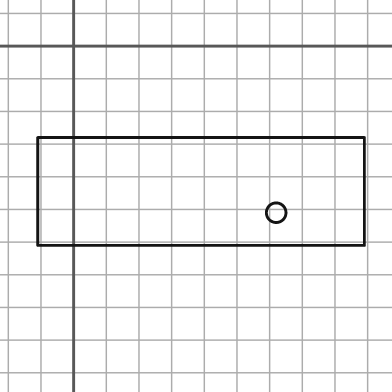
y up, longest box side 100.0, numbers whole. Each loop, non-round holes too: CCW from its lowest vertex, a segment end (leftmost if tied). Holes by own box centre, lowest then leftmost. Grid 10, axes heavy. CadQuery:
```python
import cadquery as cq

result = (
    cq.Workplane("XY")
    .moveTo(-11.0, -61.0)
    .lineTo(89.0, -61.0)
    .lineTo(89.0, -28.0)
    .lineTo(-11.0, -28.0)
    .close()
    .moveTo(62.0, -51.0)
    .circle(3.0)
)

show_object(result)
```